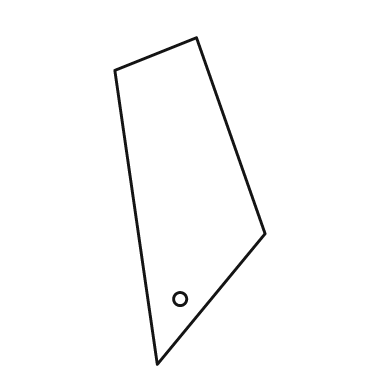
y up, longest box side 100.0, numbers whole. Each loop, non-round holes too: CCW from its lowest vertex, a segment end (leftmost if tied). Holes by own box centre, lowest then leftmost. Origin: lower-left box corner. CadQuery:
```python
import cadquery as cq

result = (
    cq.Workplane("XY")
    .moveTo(13.0, 0.0)
    .lineTo(46.0, 40.0)
    .lineTo(25.0, 100.0)
    .lineTo(0.0, 90.0)
    .close()
    .moveTo(20.0, 20.0)
    .circle(2.0)
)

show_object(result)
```